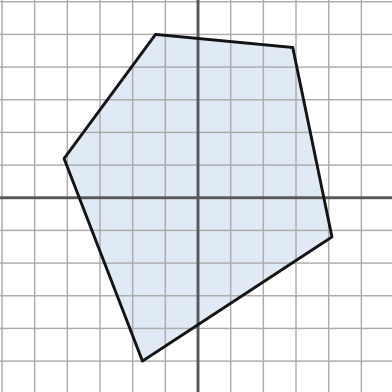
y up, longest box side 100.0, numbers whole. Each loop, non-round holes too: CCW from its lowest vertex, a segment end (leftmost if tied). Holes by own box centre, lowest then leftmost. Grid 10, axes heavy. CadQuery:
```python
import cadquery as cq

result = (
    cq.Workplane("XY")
    .moveTo(-17.0, -50.0)
    .lineTo(41.0, -12.0)
    .lineTo(29.0, 46.0)
    .lineTo(-13.0, 50.0)
    .lineTo(-41.0, 12.0)
    .close()
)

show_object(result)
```